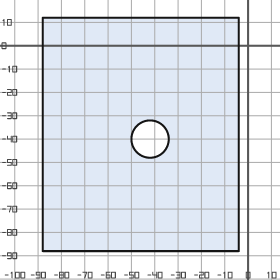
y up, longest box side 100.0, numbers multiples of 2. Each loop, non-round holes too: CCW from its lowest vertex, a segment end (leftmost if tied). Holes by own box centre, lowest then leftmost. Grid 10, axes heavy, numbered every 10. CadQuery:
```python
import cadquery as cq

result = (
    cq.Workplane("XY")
    .moveTo(-88.0, -88.0)
    .lineTo(-4.0, -88.0)
    .lineTo(-4.0, 12.0)
    .lineTo(-88.0, 12.0)
    .close()
    .moveTo(-42.0, -40.0)
    .circle(8.0)
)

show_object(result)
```